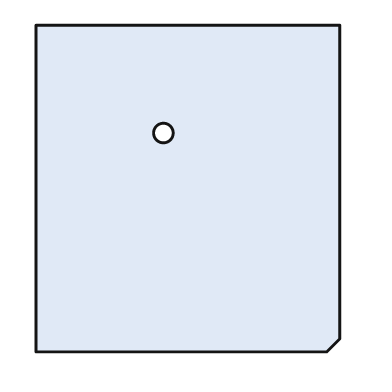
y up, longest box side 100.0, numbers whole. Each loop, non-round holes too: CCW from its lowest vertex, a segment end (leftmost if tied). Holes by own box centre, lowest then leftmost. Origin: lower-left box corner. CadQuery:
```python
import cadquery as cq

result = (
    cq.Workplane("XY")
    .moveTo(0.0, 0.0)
    .lineTo(89.0, 0.0)
    .lineTo(93.0, 4.0)
    .lineTo(93.0, 100.0)
    .lineTo(0.0, 100.0)
    .close()
    .moveTo(39.0, 67.0)
    .circle(3.0)
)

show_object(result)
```